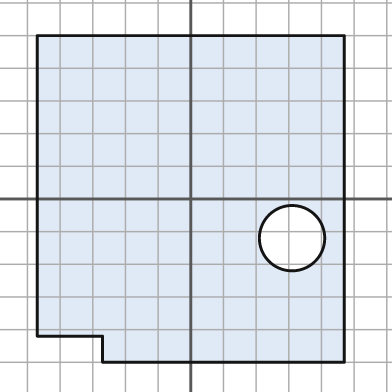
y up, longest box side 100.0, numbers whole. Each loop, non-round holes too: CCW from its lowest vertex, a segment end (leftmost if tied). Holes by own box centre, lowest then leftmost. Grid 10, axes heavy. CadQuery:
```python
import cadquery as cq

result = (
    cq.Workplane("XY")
    .moveTo(-27.0, -50.0)
    .lineTo(47.0, -50.0)
    .lineTo(47.0, 50.0)
    .lineTo(-47.0, 50.0)
    .lineTo(-47.0, -42.0)
    .lineTo(-27.0, -42.0)
    .close()
    .moveTo(31.0, -12.0)
    .circle(10.0)
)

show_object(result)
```